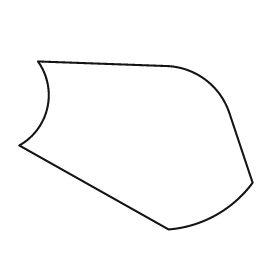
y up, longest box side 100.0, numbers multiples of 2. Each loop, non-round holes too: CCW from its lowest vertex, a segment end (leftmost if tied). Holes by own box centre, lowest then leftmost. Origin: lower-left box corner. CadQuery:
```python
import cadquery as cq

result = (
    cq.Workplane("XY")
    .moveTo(64.0, 0.0)
    .threePointArc((84.0, 6.0), (100.0, 20.0))
    .lineTo(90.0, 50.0)
    .threePointArc((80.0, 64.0), (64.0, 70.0))
    .lineTo(8.0, 72.0)
    .threePointArc((12.0, 52.0), (0.0, 36.0))
    .close()
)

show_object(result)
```